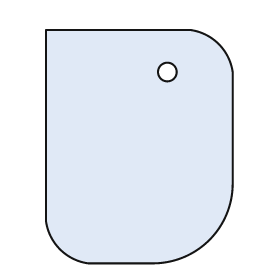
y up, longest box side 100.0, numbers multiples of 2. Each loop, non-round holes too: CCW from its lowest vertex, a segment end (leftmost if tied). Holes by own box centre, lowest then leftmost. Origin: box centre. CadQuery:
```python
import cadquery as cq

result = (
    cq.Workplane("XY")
    .moveTo(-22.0, -50.0)
    .lineTo(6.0, -50.0)
    .threePointArc((30.0, -40.0), (40.0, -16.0))
    .lineTo(40.0, 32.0)
    .threePointArc((34.0, 44.0), (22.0, 50.0))
    .lineTo(-40.0, 50.0)
    .lineTo(-40.0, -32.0)
    .threePointArc((-34.0, -44.0), (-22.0, -50.0))
    .close()
    .moveTo(12.0, 32.0)
    .circle(4.0)
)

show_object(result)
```